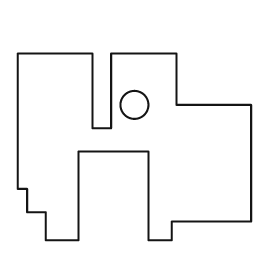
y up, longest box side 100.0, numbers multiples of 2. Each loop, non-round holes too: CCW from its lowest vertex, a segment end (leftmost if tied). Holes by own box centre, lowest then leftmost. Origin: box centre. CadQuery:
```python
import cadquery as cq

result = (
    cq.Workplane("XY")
    .moveTo(-38.0, -40.0)
    .lineTo(-24.0, -40.0)
    .lineTo(-24.0, -2.0)
    .lineTo(6.0, -2.0)
    .lineTo(6.0, -40.0)
    .lineTo(16.0, -40.0)
    .lineTo(16.0, -32.0)
    .lineTo(50.0, -32.0)
    .lineTo(50.0, 18.0)
    .lineTo(18.0, 18.0)
    .lineTo(18.0, 40.0)
    .lineTo(-10.0, 40.0)
    .lineTo(-10.0, 8.0)
    .lineTo(-18.0, 8.0)
    .lineTo(-18.0, 40.0)
    .lineTo(-50.0, 40.0)
    .lineTo(-50.0, -18.0)
    .lineTo(-46.0, -18.0)
    .lineTo(-46.0, -28.0)
    .lineTo(-38.0, -28.0)
    .close()
    .moveTo(0.0, 18.0)
    .circle(6.0)
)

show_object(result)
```